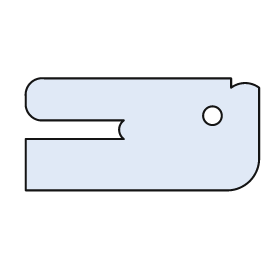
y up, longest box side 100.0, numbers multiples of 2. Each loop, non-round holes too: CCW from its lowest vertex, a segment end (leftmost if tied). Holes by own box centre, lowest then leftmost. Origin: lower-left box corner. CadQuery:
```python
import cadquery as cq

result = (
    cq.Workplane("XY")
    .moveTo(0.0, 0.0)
    .lineTo(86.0, 0.0)
    .threePointArc((96.0, 4.0), (100.0, 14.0))
    .lineTo(100.0, 44.0)
    .threePointArc((94.0, 46.0), (88.0, 44.0))
    .lineTo(88.0, 48.0)
    .lineTo(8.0, 48.0)
    .threePointArc((2.0, 46.0), (0.0, 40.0))
    .lineTo(0.0, 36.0)
    .threePointArc((2.0, 32.0), (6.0, 30.0))
    .lineTo(42.0, 30.0)
    .threePointArc((40.0, 26.0), (42.0, 22.0))
    .lineTo(0.0, 22.0)
    .close()
    .moveTo(80.0, 32.0)
    .circle(4.0)
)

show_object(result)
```